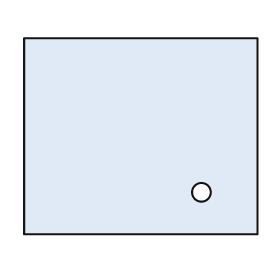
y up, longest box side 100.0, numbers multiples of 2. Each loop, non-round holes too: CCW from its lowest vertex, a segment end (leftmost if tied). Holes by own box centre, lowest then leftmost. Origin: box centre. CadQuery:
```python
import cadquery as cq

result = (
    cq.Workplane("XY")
    .moveTo(-50.0, -42.0)
    .lineTo(50.0, -42.0)
    .lineTo(50.0, 42.0)
    .lineTo(-50.0, 42.0)
    .close()
    .moveTo(26.0, -24.0)
    .circle(4.0)
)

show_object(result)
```